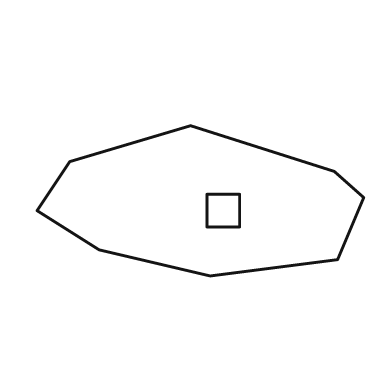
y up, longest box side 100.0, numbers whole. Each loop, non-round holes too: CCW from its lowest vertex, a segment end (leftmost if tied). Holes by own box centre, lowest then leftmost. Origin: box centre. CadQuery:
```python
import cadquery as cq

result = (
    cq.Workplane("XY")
    .moveTo(3.0, -23.0)
    .lineTo(42.0, -18.0)
    .lineTo(50.0, 1.0)
    .lineTo(41.0, 9.0)
    .lineTo(-3.0, 23.0)
    .lineTo(-40.0, 12.0)
    .lineTo(-50.0, -3.0)
    .lineTo(-31.0, -15.0)
    .close()
    .moveTo(2.0, -8.0)
    .lineTo(12.0, -8.0)
    .lineTo(12.0, 2.0)
    .lineTo(2.0, 2.0)
    .close()
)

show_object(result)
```